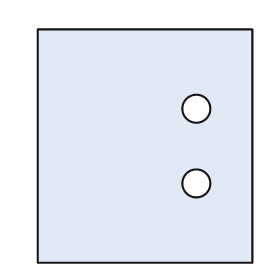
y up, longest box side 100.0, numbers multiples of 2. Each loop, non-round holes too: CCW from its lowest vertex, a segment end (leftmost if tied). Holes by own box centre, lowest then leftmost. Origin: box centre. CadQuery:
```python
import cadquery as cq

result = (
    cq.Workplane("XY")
    .moveTo(-46.0, -50.0)
    .lineTo(46.0, -50.0)
    .lineTo(46.0, 50.0)
    .lineTo(-46.0, 50.0)
    .close()
    .moveTo(22.0, -16.0)
    .circle(6.0)
    .moveTo(22.0, 16.0)
    .circle(6.0)
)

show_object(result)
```